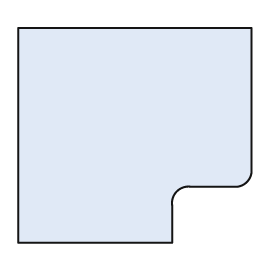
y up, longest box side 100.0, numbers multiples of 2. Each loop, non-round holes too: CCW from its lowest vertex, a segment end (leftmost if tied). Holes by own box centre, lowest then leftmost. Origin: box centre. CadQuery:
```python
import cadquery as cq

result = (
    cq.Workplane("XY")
    .moveTo(-50.0, -46.0)
    .lineTo(16.0, -46.0)
    .lineTo(16.0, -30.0)
    .threePointArc((18.0, -24.0), (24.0, -22.0))
    .lineTo(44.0, -22.0)
    .threePointArc((48.0, -20.0), (50.0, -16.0))
    .lineTo(50.0, 46.0)
    .lineTo(-50.0, 46.0)
    .close()
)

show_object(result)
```